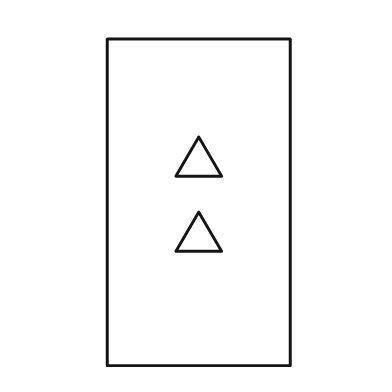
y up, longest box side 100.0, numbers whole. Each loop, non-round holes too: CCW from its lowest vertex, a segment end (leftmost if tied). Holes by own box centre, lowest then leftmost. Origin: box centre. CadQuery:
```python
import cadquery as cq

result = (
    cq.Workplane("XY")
    .moveTo(-28.0, -50.0)
    .lineTo(28.0, -50.0)
    .lineTo(28.0, 50.0)
    .lineTo(-28.0, 50.0)
    .close()
    .moveTo(-7.0, -15.0)
    .lineTo(7.0, -15.0)
    .lineTo(0.0, -3.0)
    .close()
    .moveTo(-7.0, 8.0)
    .lineTo(7.0, 8.0)
    .lineTo(0.0, 20.0)
    .close()
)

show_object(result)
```